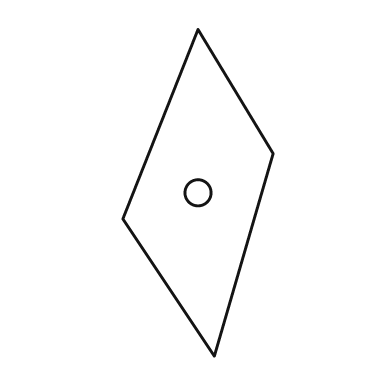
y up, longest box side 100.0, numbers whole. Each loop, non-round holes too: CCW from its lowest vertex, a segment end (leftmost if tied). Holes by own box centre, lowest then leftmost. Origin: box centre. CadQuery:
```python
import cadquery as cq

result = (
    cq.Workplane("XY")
    .moveTo(5.0, -50.0)
    .lineTo(23.0, 12.0)
    .lineTo(0.0, 50.0)
    .lineTo(-23.0, -8.0)
    .close()
    .moveTo(0.0, 0.0)
    .circle(4.0)
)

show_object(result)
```